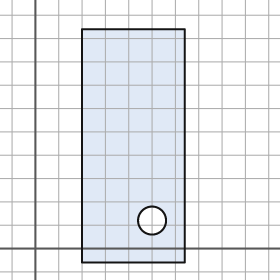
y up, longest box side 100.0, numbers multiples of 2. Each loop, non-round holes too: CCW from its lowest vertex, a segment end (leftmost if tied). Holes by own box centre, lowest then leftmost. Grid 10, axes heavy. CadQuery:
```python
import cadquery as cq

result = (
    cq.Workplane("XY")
    .moveTo(20.0, -6.0)
    .lineTo(64.0, -6.0)
    .lineTo(64.0, 94.0)
    .lineTo(20.0, 94.0)
    .close()
    .moveTo(50.0, 12.0)
    .circle(6.0)
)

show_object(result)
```